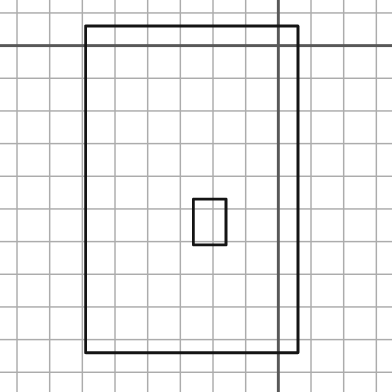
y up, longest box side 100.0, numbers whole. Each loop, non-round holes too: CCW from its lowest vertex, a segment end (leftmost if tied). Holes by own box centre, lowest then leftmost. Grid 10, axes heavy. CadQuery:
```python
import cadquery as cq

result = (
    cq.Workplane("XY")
    .moveTo(-59.0, -94.0)
    .lineTo(6.0, -94.0)
    .lineTo(6.0, 6.0)
    .lineTo(-59.0, 6.0)
    .close()
    .moveTo(-26.0, -61.0)
    .lineTo(-16.0, -61.0)
    .lineTo(-16.0, -47.0)
    .lineTo(-26.0, -47.0)
    .close()
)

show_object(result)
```